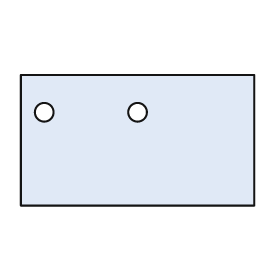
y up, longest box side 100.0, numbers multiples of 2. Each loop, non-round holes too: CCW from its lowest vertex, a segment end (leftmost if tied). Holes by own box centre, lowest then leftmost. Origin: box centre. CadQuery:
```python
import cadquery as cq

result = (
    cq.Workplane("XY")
    .moveTo(-50.0, -28.0)
    .lineTo(50.0, -28.0)
    .lineTo(50.0, 28.0)
    .lineTo(-50.0, 28.0)
    .close()
    .moveTo(-40.0, 12.0)
    .circle(4.0)
    .moveTo(0.0, 12.0)
    .circle(4.0)
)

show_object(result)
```